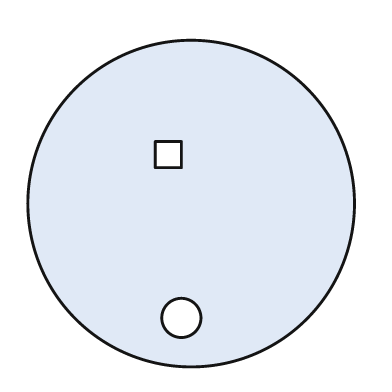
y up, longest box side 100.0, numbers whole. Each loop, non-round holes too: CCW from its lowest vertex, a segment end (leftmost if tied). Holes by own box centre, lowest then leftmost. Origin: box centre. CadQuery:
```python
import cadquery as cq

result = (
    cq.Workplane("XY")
    .moveTo(0.0, 0.0)
    .circle(50.0)
    .moveTo(-3.0, -35.0)
    .circle(6.0)
    .moveTo(-11.0, 11.0)
    .lineTo(-3.0, 11.0)
    .lineTo(-3.0, 19.0)
    .lineTo(-11.0, 19.0)
    .close()
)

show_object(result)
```